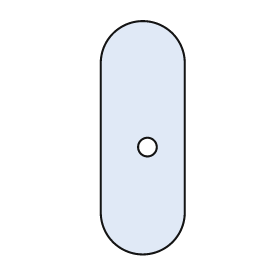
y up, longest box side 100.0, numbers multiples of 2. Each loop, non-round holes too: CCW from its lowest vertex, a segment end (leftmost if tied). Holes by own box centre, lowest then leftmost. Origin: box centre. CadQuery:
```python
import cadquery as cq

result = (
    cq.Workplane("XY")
    .moveTo(-18.0, -32.0)
    .threePointArc((0.0, -50.0), (18.0, -32.0))
    .lineTo(18.0, 32.0)
    .threePointArc((0.0, 50.0), (-18.0, 32.0))
    .close()
    .moveTo(2.0, -4.0)
    .circle(4.0)
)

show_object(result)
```